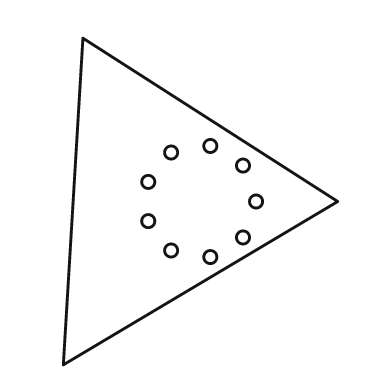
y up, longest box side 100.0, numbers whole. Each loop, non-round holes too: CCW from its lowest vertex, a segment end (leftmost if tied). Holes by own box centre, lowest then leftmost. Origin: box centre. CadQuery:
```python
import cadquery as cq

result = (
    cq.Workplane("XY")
    .moveTo(-42.0, -50.0)
    .lineTo(42.0, 0.0)
    .lineTo(-36.0, 50.0)
    .close()
    .moveTo(3.0, -17.0)
    .circle(2.0)
    .moveTo(-9.0, -15.0)
    .circle(2.0)
    .moveTo(13.0, -11.0)
    .circle(2.0)
    .moveTo(-16.0, -6.0)
    .circle(2.0)
    .moveTo(17.0, 0.0)
    .circle(2.0)
    .moveTo(-16.0, 6.0)
    .circle(2.0)
    .moveTo(13.0, 11.0)
    .circle(2.0)
    .moveTo(-9.0, 15.0)
    .circle(2.0)
    .moveTo(3.0, 17.0)
    .circle(2.0)
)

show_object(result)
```